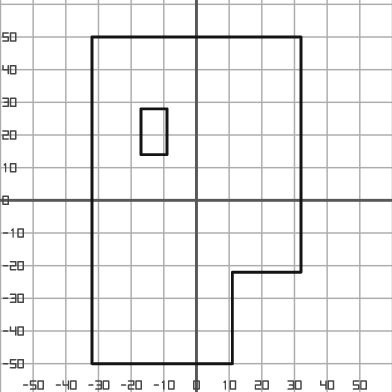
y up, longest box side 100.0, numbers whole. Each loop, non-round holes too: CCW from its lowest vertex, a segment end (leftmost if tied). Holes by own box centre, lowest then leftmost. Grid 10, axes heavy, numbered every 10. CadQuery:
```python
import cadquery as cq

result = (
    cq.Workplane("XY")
    .moveTo(-32.0, -50.0)
    .lineTo(11.0, -50.0)
    .lineTo(11.0, -22.0)
    .lineTo(32.0, -22.0)
    .lineTo(32.0, 50.0)
    .lineTo(-32.0, 50.0)
    .close()
    .moveTo(-17.0, 14.0)
    .lineTo(-9.0, 14.0)
    .lineTo(-9.0, 28.0)
    .lineTo(-17.0, 28.0)
    .close()
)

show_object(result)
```